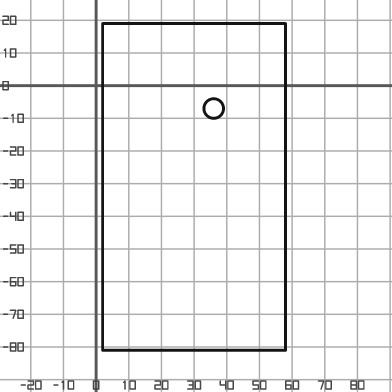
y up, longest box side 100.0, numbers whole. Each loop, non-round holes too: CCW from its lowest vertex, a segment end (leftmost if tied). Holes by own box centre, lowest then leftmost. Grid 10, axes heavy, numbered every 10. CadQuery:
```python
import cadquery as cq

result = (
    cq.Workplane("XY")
    .moveTo(2.0, -81.0)
    .lineTo(58.0, -81.0)
    .lineTo(58.0, 19.0)
    .lineTo(2.0, 19.0)
    .close()
    .moveTo(36.0, -7.0)
    .circle(3.0)
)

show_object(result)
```